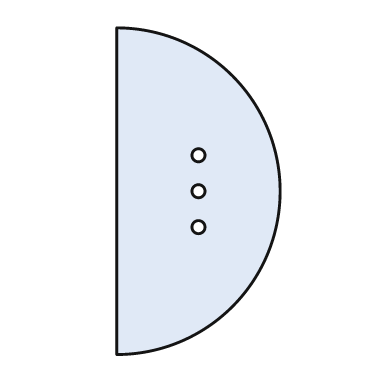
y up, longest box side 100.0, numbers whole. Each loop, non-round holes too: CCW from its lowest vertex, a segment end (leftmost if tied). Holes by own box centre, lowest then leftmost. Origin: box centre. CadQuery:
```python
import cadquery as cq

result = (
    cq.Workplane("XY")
    .moveTo(-25.0, -50.0)
    .threePointArc((25.0, 0.0), (-25.0, 50.0))
    .close()
    .moveTo(0.0, -11.0)
    .circle(2.0)
    .moveTo(0.0, 0.0)
    .circle(2.0)
    .moveTo(0.0, 11.0)
    .circle(2.0)
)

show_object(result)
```